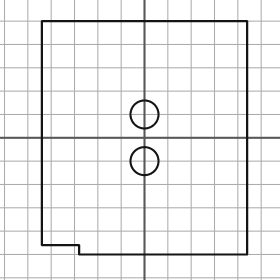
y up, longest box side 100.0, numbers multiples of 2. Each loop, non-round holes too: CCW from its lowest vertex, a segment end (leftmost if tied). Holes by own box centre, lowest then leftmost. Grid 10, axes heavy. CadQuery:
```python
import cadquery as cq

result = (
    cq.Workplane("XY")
    .moveTo(-28.0, -50.0)
    .lineTo(44.0, -50.0)
    .lineTo(44.0, 50.0)
    .lineTo(-44.0, 50.0)
    .lineTo(-44.0, -46.0)
    .lineTo(-28.0, -46.0)
    .close()
    .moveTo(0.0, -10.0)
    .circle(6.0)
    .moveTo(0.0, 10.0)
    .circle(6.0)
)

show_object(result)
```